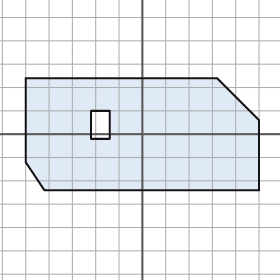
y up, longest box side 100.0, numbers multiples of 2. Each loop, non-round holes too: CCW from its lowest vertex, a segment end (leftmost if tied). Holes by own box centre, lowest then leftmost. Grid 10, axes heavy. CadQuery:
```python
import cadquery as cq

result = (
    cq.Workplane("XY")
    .moveTo(-42.0, -24.0)
    .lineTo(50.0, -24.0)
    .lineTo(50.0, 6.0)
    .lineTo(32.0, 24.0)
    .lineTo(-50.0, 24.0)
    .lineTo(-50.0, -12.0)
    .close()
    .moveTo(-22.0, -2.0)
    .lineTo(-14.0, -2.0)
    .lineTo(-14.0, 10.0)
    .lineTo(-22.0, 10.0)
    .close()
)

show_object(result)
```